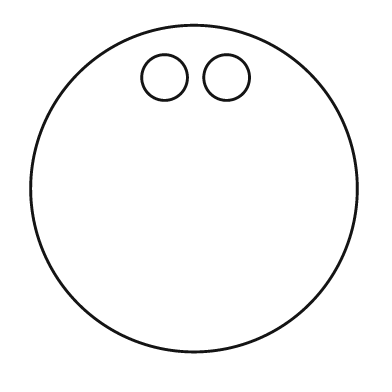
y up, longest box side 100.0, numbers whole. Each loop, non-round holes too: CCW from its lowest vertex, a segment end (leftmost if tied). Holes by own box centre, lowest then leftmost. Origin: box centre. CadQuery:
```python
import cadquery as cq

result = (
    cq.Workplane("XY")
    .moveTo(0.0, 0.0)
    .circle(50.0)
    .moveTo(-9.0, 34.0)
    .circle(7.0)
    .moveTo(10.0, 34.0)
    .circle(7.0)
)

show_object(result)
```